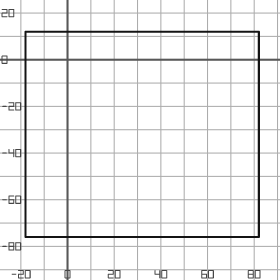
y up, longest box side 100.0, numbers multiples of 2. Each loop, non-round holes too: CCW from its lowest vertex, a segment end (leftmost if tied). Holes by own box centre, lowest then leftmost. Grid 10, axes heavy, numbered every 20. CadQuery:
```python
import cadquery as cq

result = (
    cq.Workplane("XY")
    .moveTo(-18.0, -76.0)
    .lineTo(82.0, -76.0)
    .lineTo(82.0, 12.0)
    .lineTo(-18.0, 12.0)
    .close()
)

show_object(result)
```